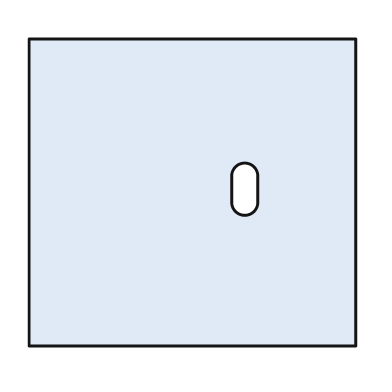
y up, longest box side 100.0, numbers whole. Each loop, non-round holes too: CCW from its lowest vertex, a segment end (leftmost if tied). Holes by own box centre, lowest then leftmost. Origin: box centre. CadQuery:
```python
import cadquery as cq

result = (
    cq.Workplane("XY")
    .moveTo(-50.0, -47.0)
    .lineTo(50.0, -47.0)
    .lineTo(50.0, 47.0)
    .lineTo(-50.0, 47.0)
    .close()
    .moveTo(12.0, -3.0)
    .threePointArc((16.0, -7.0), (20.0, -3.0))
    .lineTo(20.0, 5.0)
    .threePointArc((16.0, 9.0), (12.0, 5.0))
    .close()
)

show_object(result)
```